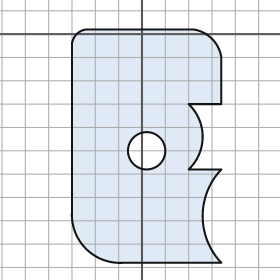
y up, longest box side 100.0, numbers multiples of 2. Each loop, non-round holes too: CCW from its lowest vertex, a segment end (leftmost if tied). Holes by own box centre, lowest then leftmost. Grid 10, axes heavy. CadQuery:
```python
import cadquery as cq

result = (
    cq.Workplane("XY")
    .moveTo(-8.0, -98.0)
    .lineTo(34.0, -98.0)
    .threePointArc((26.0, -78.0), (34.0, -58.0))
    .lineTo(20.0, -58.0)
    .threePointArc((26.0, -44.0), (20.0, -30.0))
    .lineTo(34.0, -30.0)
    .lineTo(34.0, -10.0)
    .threePointArc((30.0, -2.0), (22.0, 2.0))
    .lineTo(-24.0, 2.0)
    .threePointArc((-28.0, 0.0), (-30.0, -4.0))
    .lineTo(-30.0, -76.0)
    .threePointArc((-24.0, -92.0), (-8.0, -98.0))
    .close()
    .moveTo(2.0, -50.0)
    .circle(8.0)
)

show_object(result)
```